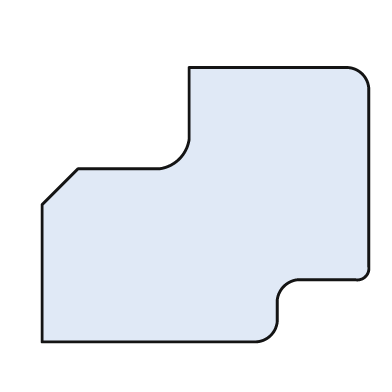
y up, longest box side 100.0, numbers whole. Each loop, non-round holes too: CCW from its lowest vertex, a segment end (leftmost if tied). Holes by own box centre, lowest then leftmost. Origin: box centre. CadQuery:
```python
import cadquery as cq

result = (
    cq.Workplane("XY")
    .moveTo(-50.0, -42.0)
    .lineTo(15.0, -42.0)
    .threePointArc((20.0, -40.0), (22.0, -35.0))
    .lineTo(22.0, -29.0)
    .threePointArc((24.0, -25.0), (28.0, -23.0))
    .lineTo(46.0, -23.0)
    .threePointArc((49.0, -22.0), (50.0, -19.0))
    .lineTo(50.0, 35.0)
    .threePointArc((48.0, 40.0), (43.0, 42.0))
    .lineTo(-5.0, 42.0)
    .lineTo(-5.0, 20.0)
    .threePointArc((-8.0, 14.0), (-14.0, 11.0))
    .lineTo(-39.0, 11.0)
    .lineTo(-50.0, 0.0)
    .close()
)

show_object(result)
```